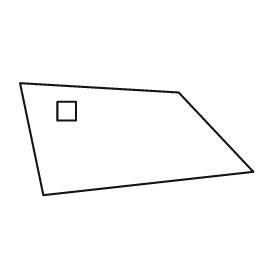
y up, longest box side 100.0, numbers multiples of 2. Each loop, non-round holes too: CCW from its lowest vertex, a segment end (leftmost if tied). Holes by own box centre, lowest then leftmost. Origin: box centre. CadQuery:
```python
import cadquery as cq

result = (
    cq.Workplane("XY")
    .moveTo(-40.0, -24.0)
    .lineTo(50.0, -14.0)
    .lineTo(18.0, 20.0)
    .lineTo(-50.0, 24.0)
    .close()
    .moveTo(-34.0, 8.0)
    .lineTo(-26.0, 8.0)
    .lineTo(-26.0, 16.0)
    .lineTo(-34.0, 16.0)
    .close()
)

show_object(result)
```